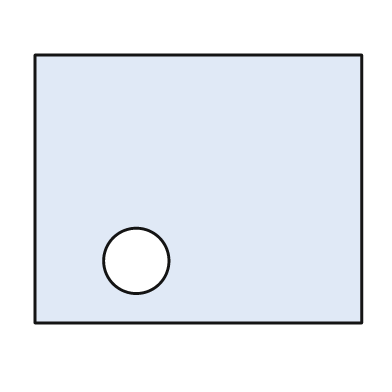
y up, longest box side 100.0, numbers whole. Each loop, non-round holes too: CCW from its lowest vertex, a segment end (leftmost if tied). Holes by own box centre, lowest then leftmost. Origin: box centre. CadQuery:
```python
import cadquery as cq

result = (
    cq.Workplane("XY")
    .moveTo(-50.0, -41.0)
    .lineTo(50.0, -41.0)
    .lineTo(50.0, 41.0)
    .lineTo(-50.0, 41.0)
    .close()
    .moveTo(-19.0, -22.0)
    .circle(10.0)
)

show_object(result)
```